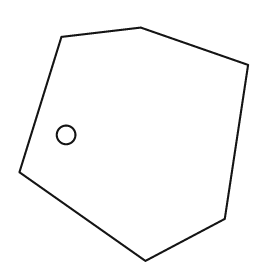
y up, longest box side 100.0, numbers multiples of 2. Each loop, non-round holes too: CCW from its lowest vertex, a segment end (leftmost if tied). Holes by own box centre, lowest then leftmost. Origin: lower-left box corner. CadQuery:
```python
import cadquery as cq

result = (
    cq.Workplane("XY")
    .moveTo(54.0, 0.0)
    .lineTo(88.0, 18.0)
    .lineTo(98.0, 84.0)
    .lineTo(52.0, 100.0)
    .lineTo(18.0, 96.0)
    .lineTo(0.0, 38.0)
    .close()
    .moveTo(20.0, 54.0)
    .circle(4.0)
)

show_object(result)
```